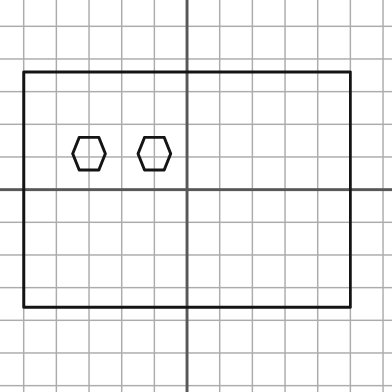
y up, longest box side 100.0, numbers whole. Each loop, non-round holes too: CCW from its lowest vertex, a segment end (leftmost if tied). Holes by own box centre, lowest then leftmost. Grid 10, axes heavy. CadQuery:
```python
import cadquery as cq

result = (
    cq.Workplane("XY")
    .moveTo(-50.0, -36.0)
    .lineTo(50.0, -36.0)
    .lineTo(50.0, 36.0)
    .lineTo(-50.0, 36.0)
    .close()
    .moveTo(-33.0, 6.0)
    .lineTo(-27.0, 6.0)
    .lineTo(-25.0, 11.0)
    .lineTo(-27.0, 16.0)
    .lineTo(-33.0, 16.0)
    .lineTo(-35.0, 11.0)
    .close()
    .moveTo(-13.0, 6.0)
    .lineTo(-7.0, 6.0)
    .lineTo(-5.0, 11.0)
    .lineTo(-7.0, 16.0)
    .lineTo(-13.0, 16.0)
    .lineTo(-15.0, 11.0)
    .close()
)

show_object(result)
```